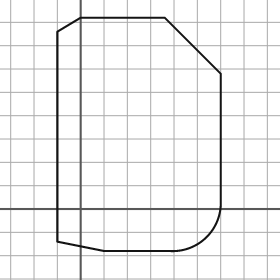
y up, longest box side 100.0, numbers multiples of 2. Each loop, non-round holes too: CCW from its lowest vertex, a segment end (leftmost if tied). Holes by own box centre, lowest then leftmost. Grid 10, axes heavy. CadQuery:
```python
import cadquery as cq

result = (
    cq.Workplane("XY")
    .moveTo(10.0, -18.0)
    .lineTo(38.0, -18.0)
    .threePointArc((54.0, -12.0), (60.0, 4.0))
    .lineTo(60.0, 58.0)
    .lineTo(36.0, 82.0)
    .lineTo(0.0, 82.0)
    .lineTo(-10.0, 76.0)
    .lineTo(-10.0, -14.0)
    .close()
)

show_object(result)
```